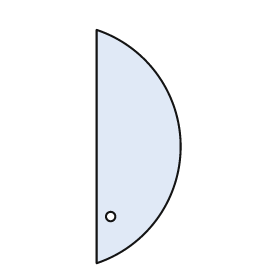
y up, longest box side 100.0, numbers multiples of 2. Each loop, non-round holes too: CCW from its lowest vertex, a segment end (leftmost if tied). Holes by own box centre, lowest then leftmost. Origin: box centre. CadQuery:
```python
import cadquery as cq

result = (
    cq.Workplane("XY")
    .moveTo(-18.0, -50.0)
    .threePointArc((18.0, 0.0), (-18.0, 50.0))
    .close()
    .moveTo(-12.0, -30.0)
    .circle(2.0)
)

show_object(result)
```